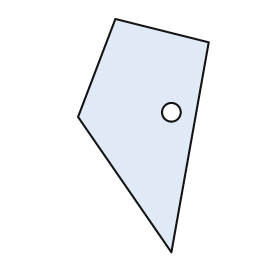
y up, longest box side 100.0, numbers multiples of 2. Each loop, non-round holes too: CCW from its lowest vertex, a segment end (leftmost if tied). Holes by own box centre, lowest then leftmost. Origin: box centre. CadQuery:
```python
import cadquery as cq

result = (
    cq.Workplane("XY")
    .moveTo(12.0, -50.0)
    .lineTo(28.0, 40.0)
    .lineTo(-12.0, 50.0)
    .lineTo(-28.0, 8.0)
    .close()
    .moveTo(12.0, 10.0)
    .circle(4.0)
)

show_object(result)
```